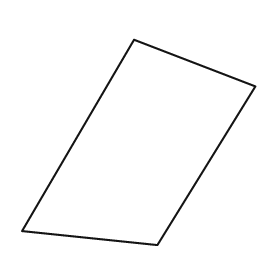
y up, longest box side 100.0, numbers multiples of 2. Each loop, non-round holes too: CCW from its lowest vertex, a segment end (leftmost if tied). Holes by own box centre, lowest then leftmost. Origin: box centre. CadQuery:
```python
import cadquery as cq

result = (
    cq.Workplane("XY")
    .moveTo(8.0, -44.0)
    .lineTo(50.0, 24.0)
    .lineTo(-2.0, 44.0)
    .lineTo(-50.0, -38.0)
    .close()
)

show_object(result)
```